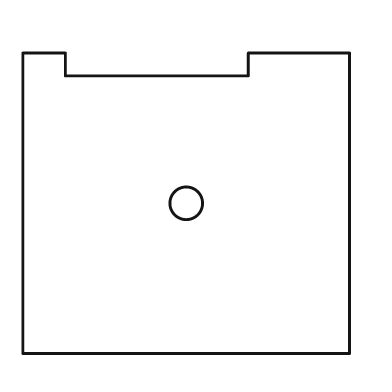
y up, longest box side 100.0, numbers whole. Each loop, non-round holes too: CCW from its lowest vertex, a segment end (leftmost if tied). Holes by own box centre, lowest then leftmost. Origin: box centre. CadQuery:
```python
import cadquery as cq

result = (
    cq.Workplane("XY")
    .moveTo(-50.0, -46.0)
    .lineTo(50.0, -46.0)
    .lineTo(50.0, 46.0)
    .lineTo(19.0, 46.0)
    .lineTo(19.0, 39.0)
    .lineTo(-37.0, 39.0)
    .lineTo(-37.0, 46.0)
    .lineTo(-50.0, 46.0)
    .close()
    .moveTo(0.0, 0.0)
    .circle(5.0)
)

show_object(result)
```